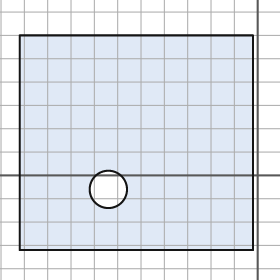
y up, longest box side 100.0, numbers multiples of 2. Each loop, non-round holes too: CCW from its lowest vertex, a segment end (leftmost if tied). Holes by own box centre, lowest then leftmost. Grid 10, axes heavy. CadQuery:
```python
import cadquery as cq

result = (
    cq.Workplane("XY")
    .moveTo(-102.0, -32.0)
    .lineTo(-2.0, -32.0)
    .lineTo(-2.0, 60.0)
    .lineTo(-102.0, 60.0)
    .close()
    .moveTo(-64.0, -6.0)
    .circle(8.0)
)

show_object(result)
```